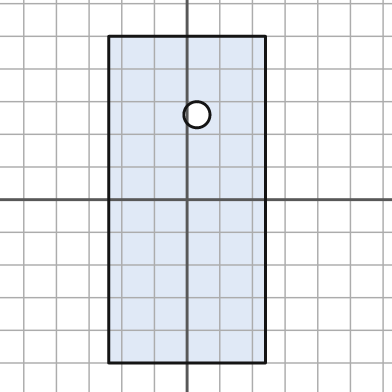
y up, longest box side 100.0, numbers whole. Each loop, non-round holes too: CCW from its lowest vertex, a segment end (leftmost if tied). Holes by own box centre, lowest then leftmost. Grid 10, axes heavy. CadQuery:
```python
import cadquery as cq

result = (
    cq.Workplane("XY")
    .moveTo(-24.0, -50.0)
    .lineTo(24.0, -50.0)
    .lineTo(24.0, 50.0)
    .lineTo(-24.0, 50.0)
    .close()
    .moveTo(3.0, 26.0)
    .circle(4.0)
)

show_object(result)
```